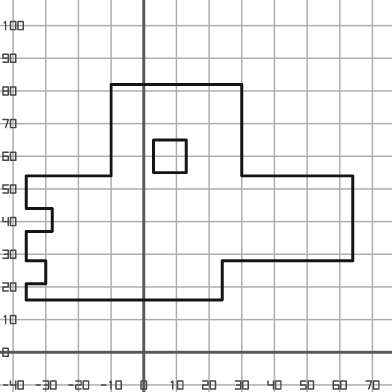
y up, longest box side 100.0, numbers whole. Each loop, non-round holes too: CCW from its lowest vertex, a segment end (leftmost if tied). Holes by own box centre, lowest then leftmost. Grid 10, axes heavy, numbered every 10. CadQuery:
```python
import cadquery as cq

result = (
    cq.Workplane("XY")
    .moveTo(-36.0, 16.0)
    .lineTo(24.0, 16.0)
    .lineTo(24.0, 28.0)
    .lineTo(64.0, 28.0)
    .lineTo(64.0, 54.0)
    .lineTo(30.0, 54.0)
    .lineTo(30.0, 82.0)
    .lineTo(-10.0, 82.0)
    .lineTo(-10.0, 54.0)
    .lineTo(-36.0, 54.0)
    .lineTo(-36.0, 44.0)
    .lineTo(-28.0, 44.0)
    .lineTo(-28.0, 37.0)
    .lineTo(-36.0, 37.0)
    .lineTo(-36.0, 28.0)
    .lineTo(-30.0, 28.0)
    .lineTo(-30.0, 21.0)
    .lineTo(-36.0, 21.0)
    .close()
    .moveTo(3.0, 55.0)
    .lineTo(13.0, 55.0)
    .lineTo(13.0, 65.0)
    .lineTo(3.0, 65.0)
    .close()
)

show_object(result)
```